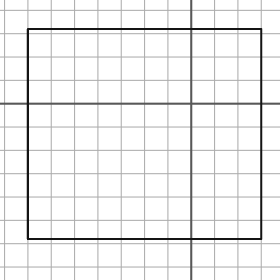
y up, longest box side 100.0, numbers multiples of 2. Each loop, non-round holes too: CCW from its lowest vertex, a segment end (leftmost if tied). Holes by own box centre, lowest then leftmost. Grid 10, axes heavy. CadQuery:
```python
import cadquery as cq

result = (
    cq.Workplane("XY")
    .moveTo(-70.0, -58.0)
    .lineTo(30.0, -58.0)
    .lineTo(30.0, 32.0)
    .lineTo(-70.0, 32.0)
    .close()
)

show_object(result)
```